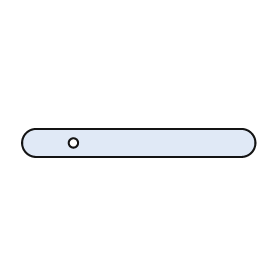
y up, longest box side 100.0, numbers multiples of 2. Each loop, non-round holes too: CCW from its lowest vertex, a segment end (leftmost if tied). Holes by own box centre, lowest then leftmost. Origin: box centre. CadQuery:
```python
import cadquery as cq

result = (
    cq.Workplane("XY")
    .moveTo(-44.0, -6.0)
    .lineTo(44.0, -6.0)
    .threePointArc((50.0, 0.0), (44.0, 6.0))
    .lineTo(-44.0, 6.0)
    .threePointArc((-50.0, 0.0), (-44.0, -6.0))
    .close()
    .moveTo(-28.0, 0.0)
    .circle(2.0)
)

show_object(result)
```